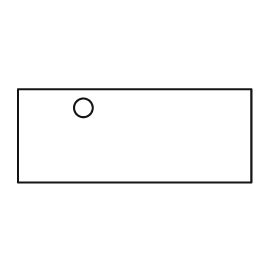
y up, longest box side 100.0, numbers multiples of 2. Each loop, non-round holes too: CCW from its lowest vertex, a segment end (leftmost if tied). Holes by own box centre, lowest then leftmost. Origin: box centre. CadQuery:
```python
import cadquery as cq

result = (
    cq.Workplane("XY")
    .moveTo(-50.0, -20.0)
    .lineTo(50.0, -20.0)
    .lineTo(50.0, 20.0)
    .lineTo(-50.0, 20.0)
    .close()
    .moveTo(-22.0, 12.0)
    .circle(4.0)
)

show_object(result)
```